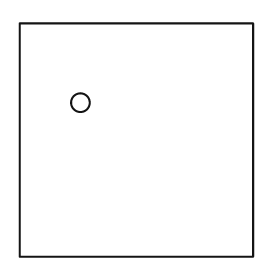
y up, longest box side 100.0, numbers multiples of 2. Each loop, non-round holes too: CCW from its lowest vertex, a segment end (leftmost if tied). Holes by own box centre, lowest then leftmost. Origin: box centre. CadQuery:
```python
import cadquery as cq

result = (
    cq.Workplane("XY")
    .moveTo(-50.0, -50.0)
    .lineTo(50.0, -50.0)
    .lineTo(50.0, 50.0)
    .lineTo(-50.0, 50.0)
    .close()
    .moveTo(-24.0, 16.0)
    .circle(4.0)
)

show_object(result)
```